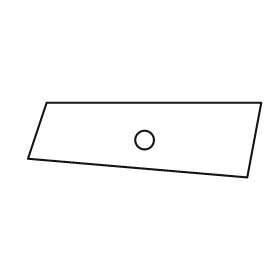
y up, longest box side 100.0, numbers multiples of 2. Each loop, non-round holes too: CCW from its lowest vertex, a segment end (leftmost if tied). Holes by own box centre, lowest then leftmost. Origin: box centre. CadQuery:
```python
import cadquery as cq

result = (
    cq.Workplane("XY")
    .moveTo(44.0, -16.0)
    .lineTo(50.0, 16.0)
    .lineTo(-42.0, 16.0)
    .lineTo(-50.0, -8.0)
    .close()
    .moveTo(0.0, 0.0)
    .circle(4.0)
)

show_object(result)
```